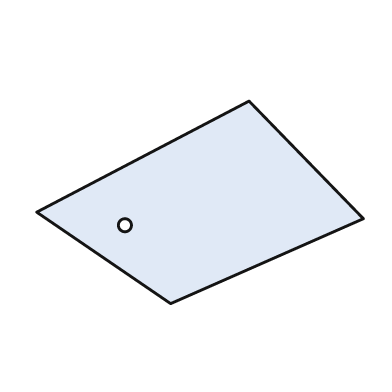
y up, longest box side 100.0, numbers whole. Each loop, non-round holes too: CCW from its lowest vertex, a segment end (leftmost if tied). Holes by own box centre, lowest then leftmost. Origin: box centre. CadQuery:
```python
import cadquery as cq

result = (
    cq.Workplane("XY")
    .moveTo(-9.0, -31.0)
    .lineTo(50.0, -5.0)
    .lineTo(15.0, 31.0)
    .lineTo(-50.0, -3.0)
    .close()
    .moveTo(-23.0, -7.0)
    .circle(2.0)
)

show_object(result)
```